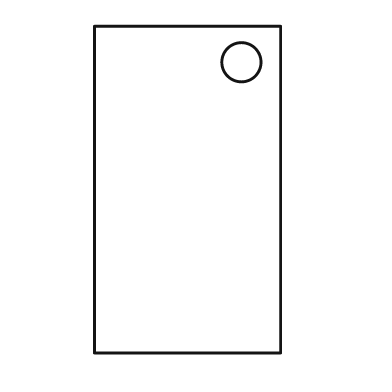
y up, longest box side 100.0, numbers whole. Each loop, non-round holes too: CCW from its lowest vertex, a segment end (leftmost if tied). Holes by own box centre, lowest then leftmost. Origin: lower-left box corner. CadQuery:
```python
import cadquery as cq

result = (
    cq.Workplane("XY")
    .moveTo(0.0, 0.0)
    .lineTo(57.0, 0.0)
    .lineTo(57.0, 100.0)
    .lineTo(0.0, 100.0)
    .close()
    .moveTo(45.0, 89.0)
    .circle(6.0)
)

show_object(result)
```